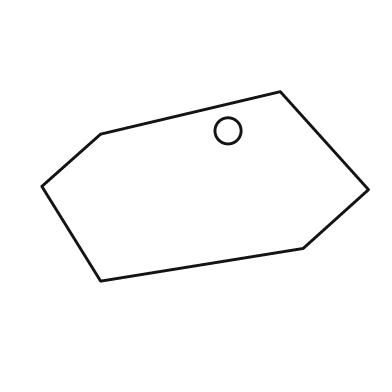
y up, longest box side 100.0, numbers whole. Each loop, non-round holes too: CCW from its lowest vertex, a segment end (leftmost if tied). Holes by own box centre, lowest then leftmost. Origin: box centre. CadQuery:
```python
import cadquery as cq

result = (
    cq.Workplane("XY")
    .moveTo(-32.0, -29.0)
    .lineTo(30.0, -19.0)
    .lineTo(50.0, -1.0)
    .lineTo(23.0, 29.0)
    .lineTo(-32.0, 16.0)
    .lineTo(-50.0, 0.0)
    .close()
    .moveTo(7.0, 17.0)
    .circle(4.0)
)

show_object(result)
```